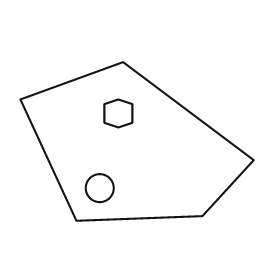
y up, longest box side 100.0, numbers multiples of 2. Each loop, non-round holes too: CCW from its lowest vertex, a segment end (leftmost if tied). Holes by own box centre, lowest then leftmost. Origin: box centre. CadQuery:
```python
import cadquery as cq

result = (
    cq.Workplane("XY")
    .moveTo(-26.0, -34.0)
    .lineTo(28.0, -32.0)
    .lineTo(50.0, -8.0)
    .lineTo(-6.0, 34.0)
    .lineTo(-50.0, 18.0)
    .close()
    .moveTo(-16.0, -20.0)
    .circle(6.0)
    .moveTo(-8.0, 6.0)
    .lineTo(-2.0, 8.0)
    .lineTo(-2.0, 16.0)
    .lineTo(-8.0, 18.0)
    .lineTo(-14.0, 16.0)
    .lineTo(-14.0, 8.0)
    .close()
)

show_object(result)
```